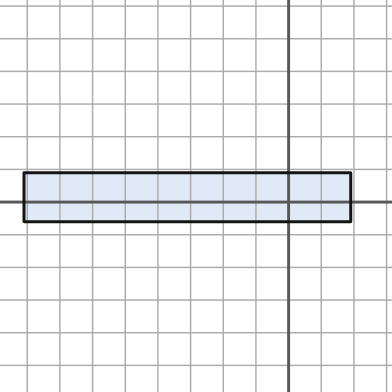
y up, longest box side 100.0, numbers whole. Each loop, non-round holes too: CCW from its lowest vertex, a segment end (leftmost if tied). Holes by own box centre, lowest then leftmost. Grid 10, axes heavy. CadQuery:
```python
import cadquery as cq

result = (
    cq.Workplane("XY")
    .moveTo(-81.0, -6.0)
    .lineTo(19.0, -6.0)
    .lineTo(19.0, 9.0)
    .lineTo(-81.0, 9.0)
    .close()
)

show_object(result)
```